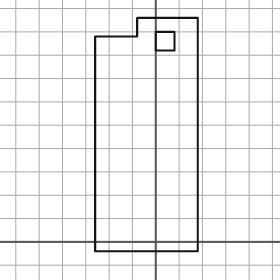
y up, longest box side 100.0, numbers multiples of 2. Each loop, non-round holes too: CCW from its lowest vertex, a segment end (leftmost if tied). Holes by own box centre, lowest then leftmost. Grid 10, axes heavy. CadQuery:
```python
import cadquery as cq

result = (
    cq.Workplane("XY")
    .moveTo(-26.0, -4.0)
    .lineTo(18.0, -4.0)
    .lineTo(18.0, 96.0)
    .lineTo(-8.0, 96.0)
    .lineTo(-8.0, 88.0)
    .lineTo(-26.0, 88.0)
    .close()
    .moveTo(0.0, 82.0)
    .lineTo(8.0, 82.0)
    .lineTo(8.0, 90.0)
    .lineTo(0.0, 90.0)
    .close()
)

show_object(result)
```